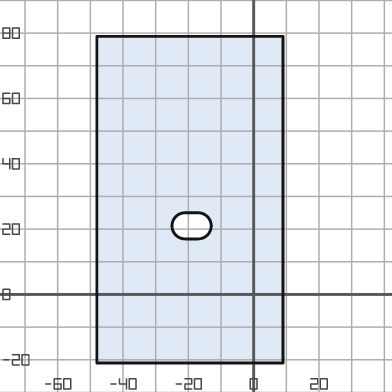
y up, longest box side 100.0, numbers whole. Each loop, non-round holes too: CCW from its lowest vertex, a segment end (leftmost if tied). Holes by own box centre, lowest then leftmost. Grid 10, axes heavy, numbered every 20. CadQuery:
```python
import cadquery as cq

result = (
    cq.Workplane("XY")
    .moveTo(-48.0, -21.0)
    .lineTo(9.0, -21.0)
    .lineTo(9.0, 79.0)
    .lineTo(-48.0, 79.0)
    .close()
    .moveTo(-21.0, 17.0)
    .lineTo(-17.0, 17.0)
    .threePointArc((-13.0, 21.0), (-17.0, 25.0))
    .lineTo(-21.0, 25.0)
    .threePointArc((-25.0, 21.0), (-21.0, 17.0))
    .close()
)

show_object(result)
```